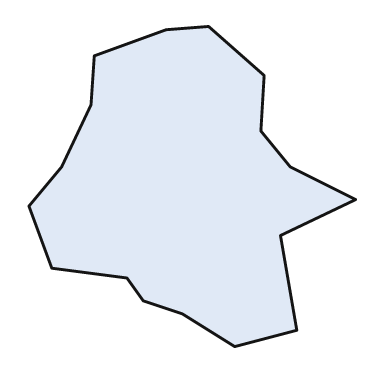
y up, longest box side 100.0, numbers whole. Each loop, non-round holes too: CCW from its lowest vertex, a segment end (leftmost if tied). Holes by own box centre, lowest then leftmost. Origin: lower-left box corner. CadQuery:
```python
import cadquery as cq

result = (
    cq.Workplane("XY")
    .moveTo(63.0, 0.0)
    .lineTo(82.0, 5.0)
    .lineTo(77.0, 34.0)
    .lineTo(100.0, 45.0)
    .lineTo(80.0, 55.0)
    .lineTo(71.0, 66.0)
    .lineTo(72.0, 83.0)
    .lineTo(55.0, 98.0)
    .lineTo(42.0, 97.0)
    .lineTo(20.0, 89.0)
    .lineTo(19.0, 74.0)
    .lineTo(10.0, 55.0)
    .lineTo(0.0, 43.0)
    .lineTo(7.0, 24.0)
    .lineTo(30.0, 21.0)
    .lineTo(35.0, 14.0)
    .lineTo(47.0, 10.0)
    .close()
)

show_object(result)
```